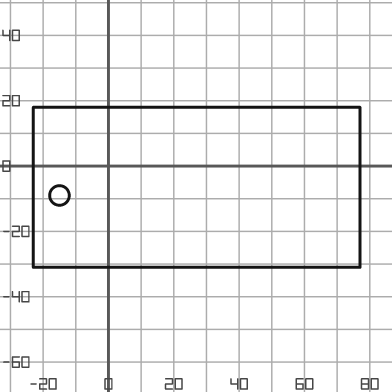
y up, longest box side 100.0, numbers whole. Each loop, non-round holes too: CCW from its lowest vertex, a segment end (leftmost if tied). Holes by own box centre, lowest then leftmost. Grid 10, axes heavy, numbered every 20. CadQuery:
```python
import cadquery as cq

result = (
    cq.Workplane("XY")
    .moveTo(-23.0, -31.0)
    .lineTo(77.0, -31.0)
    .lineTo(77.0, 18.0)
    .lineTo(-23.0, 18.0)
    .close()
    .moveTo(-15.0, -9.0)
    .circle(3.0)
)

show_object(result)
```